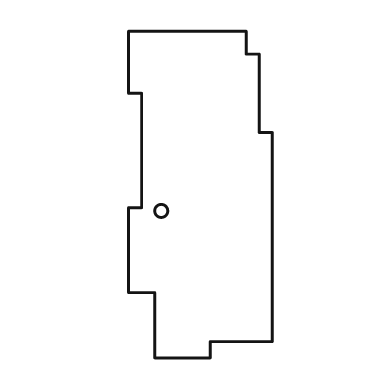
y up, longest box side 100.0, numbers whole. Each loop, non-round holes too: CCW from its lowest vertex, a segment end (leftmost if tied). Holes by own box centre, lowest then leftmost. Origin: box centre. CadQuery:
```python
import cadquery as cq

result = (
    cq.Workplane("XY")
    .moveTo(-14.0, -50.0)
    .lineTo(3.0, -50.0)
    .lineTo(3.0, -45.0)
    .lineTo(22.0, -45.0)
    .lineTo(22.0, 19.0)
    .lineTo(18.0, 19.0)
    .lineTo(18.0, 43.0)
    .lineTo(14.0, 43.0)
    .lineTo(14.0, 50.0)
    .lineTo(-22.0, 50.0)
    .lineTo(-22.0, 31.0)
    .lineTo(-18.0, 31.0)
    .lineTo(-18.0, -4.0)
    .lineTo(-22.0, -4.0)
    .lineTo(-22.0, -30.0)
    .lineTo(-14.0, -30.0)
    .close()
    .moveTo(-12.0, -5.0)
    .circle(2.0)
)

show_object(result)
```